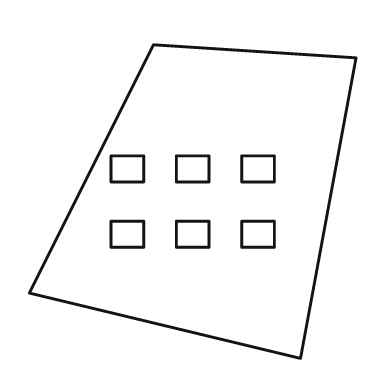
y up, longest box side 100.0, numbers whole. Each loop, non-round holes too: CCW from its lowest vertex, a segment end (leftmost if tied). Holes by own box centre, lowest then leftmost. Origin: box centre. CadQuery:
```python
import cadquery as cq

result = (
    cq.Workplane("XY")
    .moveTo(33.0, -48.0)
    .lineTo(50.0, 44.0)
    .lineTo(-12.0, 48.0)
    .lineTo(-50.0, -28.0)
    .close()
    .moveTo(-25.0, -14.0)
    .lineTo(-15.0, -14.0)
    .lineTo(-15.0, -6.0)
    .lineTo(-25.0, -6.0)
    .close()
    .moveTo(-5.0, -14.0)
    .lineTo(5.0, -14.0)
    .lineTo(5.0, -6.0)
    .lineTo(-5.0, -6.0)
    .close()
    .moveTo(15.0, -14.0)
    .lineTo(25.0, -14.0)
    .lineTo(25.0, -6.0)
    .lineTo(15.0, -6.0)
    .close()
    .moveTo(-25.0, 6.0)
    .lineTo(-15.0, 6.0)
    .lineTo(-15.0, 14.0)
    .lineTo(-25.0, 14.0)
    .close()
    .moveTo(-5.0, 6.0)
    .lineTo(5.0, 6.0)
    .lineTo(5.0, 14.0)
    .lineTo(-5.0, 14.0)
    .close()
    .moveTo(15.0, 6.0)
    .lineTo(25.0, 6.0)
    .lineTo(25.0, 14.0)
    .lineTo(15.0, 14.0)
    .close()
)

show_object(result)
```